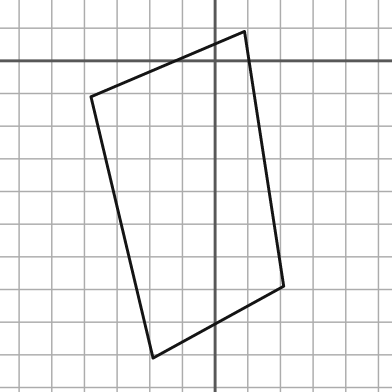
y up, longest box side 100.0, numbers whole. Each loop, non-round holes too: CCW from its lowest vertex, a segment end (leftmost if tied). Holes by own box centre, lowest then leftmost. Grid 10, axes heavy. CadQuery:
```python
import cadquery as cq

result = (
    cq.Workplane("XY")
    .moveTo(-19.0, -91.0)
    .lineTo(21.0, -69.0)
    .lineTo(9.0, 9.0)
    .lineTo(-38.0, -11.0)
    .close()
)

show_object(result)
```